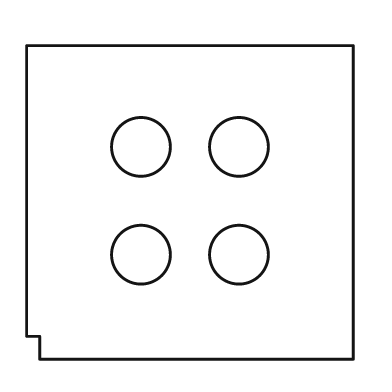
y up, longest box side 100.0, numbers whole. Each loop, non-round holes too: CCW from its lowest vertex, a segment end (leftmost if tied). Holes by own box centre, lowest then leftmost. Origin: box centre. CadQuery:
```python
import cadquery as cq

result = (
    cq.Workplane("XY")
    .moveTo(-46.0, -48.0)
    .lineTo(50.0, -48.0)
    .lineTo(50.0, 48.0)
    .lineTo(-50.0, 48.0)
    .lineTo(-50.0, -41.0)
    .lineTo(-46.0, -41.0)
    .close()
    .moveTo(-15.0, -16.0)
    .circle(9.0)
    .moveTo(15.0, -16.0)
    .circle(9.0)
    .moveTo(-15.0, 17.0)
    .circle(9.0)
    .moveTo(15.0, 17.0)
    .circle(9.0)
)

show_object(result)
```